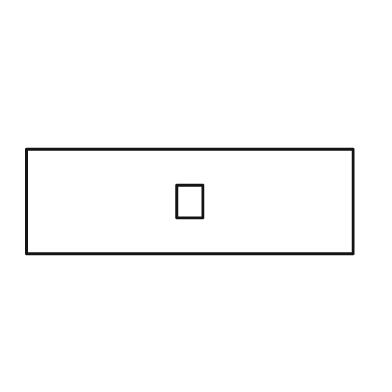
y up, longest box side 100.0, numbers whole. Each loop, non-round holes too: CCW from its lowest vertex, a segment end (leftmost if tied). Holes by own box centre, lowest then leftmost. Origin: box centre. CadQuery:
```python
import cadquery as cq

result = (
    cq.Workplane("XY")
    .moveTo(-50.0, -16.0)
    .lineTo(50.0, -16.0)
    .lineTo(50.0, 16.0)
    .lineTo(-50.0, 16.0)
    .close()
    .moveTo(-4.0, -5.0)
    .lineTo(4.0, -5.0)
    .lineTo(4.0, 5.0)
    .lineTo(-4.0, 5.0)
    .close()
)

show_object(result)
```